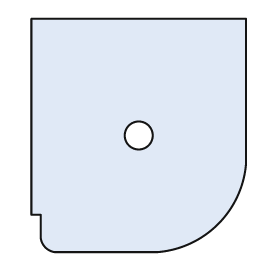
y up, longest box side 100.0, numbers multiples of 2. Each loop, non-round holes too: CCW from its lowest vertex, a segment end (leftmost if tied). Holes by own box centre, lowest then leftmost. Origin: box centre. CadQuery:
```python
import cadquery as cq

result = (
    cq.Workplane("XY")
    .moveTo(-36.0, -50.0)
    .lineTo(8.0, -50.0)
    .threePointArc((34.0, -38.0), (46.0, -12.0))
    .lineTo(46.0, 50.0)
    .lineTo(-46.0, 50.0)
    .lineTo(-46.0, -34.0)
    .lineTo(-42.0, -34.0)
    .lineTo(-42.0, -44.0)
    .threePointArc((-40.0, -48.0), (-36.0, -50.0))
    .close()
    .moveTo(0.0, 0.0)
    .circle(6.0)
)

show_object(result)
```